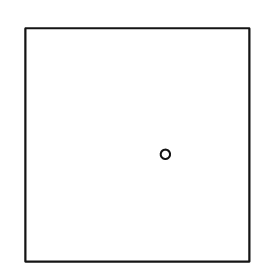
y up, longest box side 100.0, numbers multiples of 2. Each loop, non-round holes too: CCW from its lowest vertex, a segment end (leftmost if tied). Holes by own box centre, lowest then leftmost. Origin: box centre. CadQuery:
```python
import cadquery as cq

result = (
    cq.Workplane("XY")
    .moveTo(-48.0, -50.0)
    .lineTo(48.0, -50.0)
    .lineTo(48.0, 50.0)
    .lineTo(-48.0, 50.0)
    .close()
    .moveTo(12.0, -4.0)
    .circle(2.0)
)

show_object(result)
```